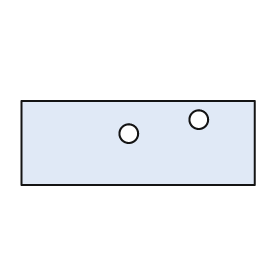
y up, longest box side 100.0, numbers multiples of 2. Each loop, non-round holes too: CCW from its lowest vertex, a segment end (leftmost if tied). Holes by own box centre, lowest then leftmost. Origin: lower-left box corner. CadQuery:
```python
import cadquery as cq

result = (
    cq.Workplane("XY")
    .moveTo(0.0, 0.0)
    .lineTo(100.0, 0.0)
    .lineTo(100.0, 36.0)
    .lineTo(0.0, 36.0)
    .close()
    .moveTo(46.0, 22.0)
    .circle(4.0)
    .moveTo(76.0, 28.0)
    .circle(4.0)
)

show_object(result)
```